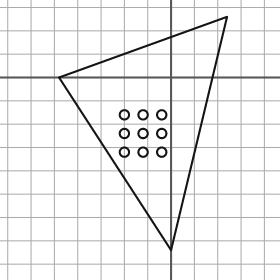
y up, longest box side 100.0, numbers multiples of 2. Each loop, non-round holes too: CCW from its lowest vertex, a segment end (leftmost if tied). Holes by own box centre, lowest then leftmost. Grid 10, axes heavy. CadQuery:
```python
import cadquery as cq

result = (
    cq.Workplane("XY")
    .moveTo(0.0, -74.0)
    .lineTo(24.0, 26.0)
    .lineTo(-48.0, 0.0)
    .close()
    .moveTo(-20.0, -32.0)
    .circle(2.0)
    .moveTo(-12.0, -32.0)
    .circle(2.0)
    .moveTo(-4.0, -32.0)
    .circle(2.0)
    .moveTo(-20.0, -24.0)
    .circle(2.0)
    .moveTo(-12.0, -24.0)
    .circle(2.0)
    .moveTo(-4.0, -24.0)
    .circle(2.0)
    .moveTo(-20.0, -16.0)
    .circle(2.0)
    .moveTo(-12.0, -16.0)
    .circle(2.0)
    .moveTo(-4.0, -16.0)
    .circle(2.0)
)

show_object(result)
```